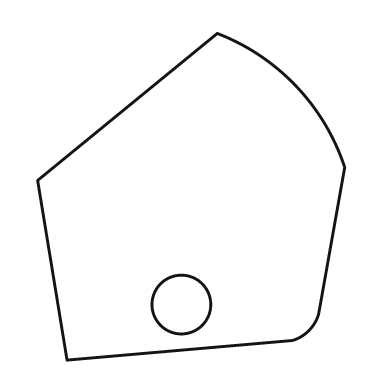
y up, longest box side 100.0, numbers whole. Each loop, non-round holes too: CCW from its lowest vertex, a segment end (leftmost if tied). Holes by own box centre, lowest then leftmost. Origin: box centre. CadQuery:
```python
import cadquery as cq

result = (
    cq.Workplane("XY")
    .moveTo(-38.0, -50.0)
    .lineTo(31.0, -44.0)
    .threePointArc((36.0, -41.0), (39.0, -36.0))
    .lineTo(47.0, 9.0)
    .threePointArc((32.0, 34.0), (8.0, 50.0))
    .lineTo(-47.0, 5.0)
    .close()
    .moveTo(-3.0, -33.0)
    .circle(9.0)
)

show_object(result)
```